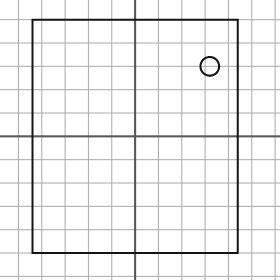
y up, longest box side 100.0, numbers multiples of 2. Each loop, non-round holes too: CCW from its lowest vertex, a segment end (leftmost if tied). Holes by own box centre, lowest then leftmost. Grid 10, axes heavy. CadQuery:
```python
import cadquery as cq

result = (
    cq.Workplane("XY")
    .moveTo(-44.0, -50.0)
    .lineTo(44.0, -50.0)
    .lineTo(44.0, 50.0)
    .lineTo(-44.0, 50.0)
    .close()
    .moveTo(32.0, 30.0)
    .circle(4.0)
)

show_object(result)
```